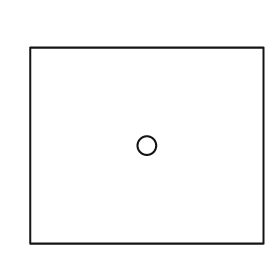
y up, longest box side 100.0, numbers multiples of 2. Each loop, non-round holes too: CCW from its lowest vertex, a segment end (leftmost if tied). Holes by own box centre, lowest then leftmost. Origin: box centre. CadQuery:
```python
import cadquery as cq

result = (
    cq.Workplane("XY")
    .moveTo(-50.0, -42.0)
    .lineTo(50.0, -42.0)
    .lineTo(50.0, 42.0)
    .lineTo(-50.0, 42.0)
    .close()
    .moveTo(0.0, 0.0)
    .circle(4.0)
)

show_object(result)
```